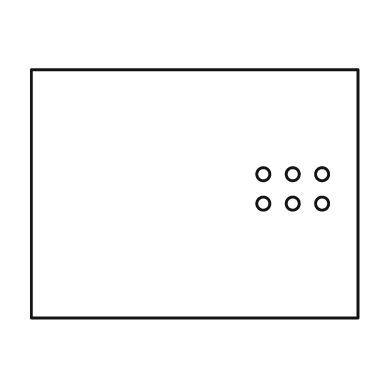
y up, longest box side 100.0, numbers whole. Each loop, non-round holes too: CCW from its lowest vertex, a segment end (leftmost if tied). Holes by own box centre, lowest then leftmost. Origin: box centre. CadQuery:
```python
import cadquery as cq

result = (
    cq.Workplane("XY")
    .moveTo(-50.0, -38.0)
    .lineTo(50.0, -38.0)
    .lineTo(50.0, 38.0)
    .lineTo(-50.0, 38.0)
    .close()
    .moveTo(21.0, -3.0)
    .circle(2.0)
    .moveTo(30.0, -3.0)
    .circle(2.0)
    .moveTo(39.0, -3.0)
    .circle(2.0)
    .moveTo(21.0, 6.0)
    .circle(2.0)
    .moveTo(30.0, 6.0)
    .circle(2.0)
    .moveTo(39.0, 6.0)
    .circle(2.0)
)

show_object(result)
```